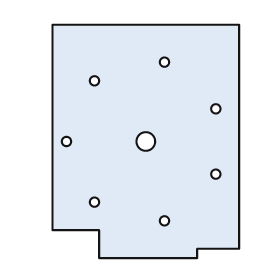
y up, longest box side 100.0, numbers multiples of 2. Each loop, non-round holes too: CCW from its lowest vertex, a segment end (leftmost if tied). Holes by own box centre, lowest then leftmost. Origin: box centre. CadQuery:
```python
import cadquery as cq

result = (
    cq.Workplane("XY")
    .moveTo(-20.0, -50.0)
    .lineTo(22.0, -50.0)
    .lineTo(22.0, -46.0)
    .lineTo(40.0, -46.0)
    .lineTo(40.0, 50.0)
    .lineTo(-40.0, 50.0)
    .lineTo(-40.0, -38.0)
    .lineTo(-20.0, -38.0)
    .close()
    .moveTo(8.0, -34.0)
    .circle(2.0)
    .moveTo(-22.0, -26.0)
    .circle(2.0)
    .moveTo(30.0, -14.0)
    .circle(2.0)
    .moveTo(-34.0, 0.0)
    .circle(2.0)
    .moveTo(0.0, 0.0)
    .circle(4.0)
    .moveTo(30.0, 14.0)
    .circle(2.0)
    .moveTo(-22.0, 26.0)
    .circle(2.0)
    .moveTo(8.0, 34.0)
    .circle(2.0)
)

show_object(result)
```